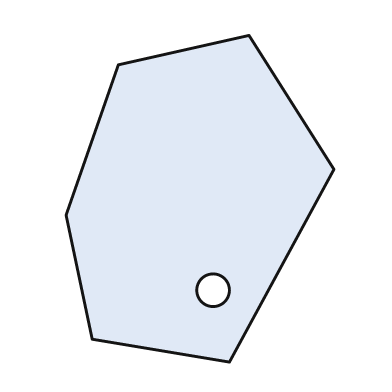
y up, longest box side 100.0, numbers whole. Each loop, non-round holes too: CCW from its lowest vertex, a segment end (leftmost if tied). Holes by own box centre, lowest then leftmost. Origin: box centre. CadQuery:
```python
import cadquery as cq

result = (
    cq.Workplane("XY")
    .moveTo(9.0, -50.0)
    .lineTo(41.0, 9.0)
    .lineTo(15.0, 50.0)
    .lineTo(-25.0, 41.0)
    .lineTo(-41.0, -5.0)
    .lineTo(-33.0, -43.0)
    .close()
    .moveTo(4.0, -28.0)
    .circle(5.0)
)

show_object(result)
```